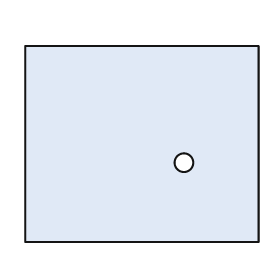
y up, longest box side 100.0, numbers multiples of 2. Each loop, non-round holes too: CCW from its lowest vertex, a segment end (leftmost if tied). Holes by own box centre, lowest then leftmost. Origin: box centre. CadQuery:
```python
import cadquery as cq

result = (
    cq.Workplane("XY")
    .moveTo(-50.0, -42.0)
    .lineTo(50.0, -42.0)
    .lineTo(50.0, 42.0)
    .lineTo(-50.0, 42.0)
    .close()
    .moveTo(18.0, -8.0)
    .circle(4.0)
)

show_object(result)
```